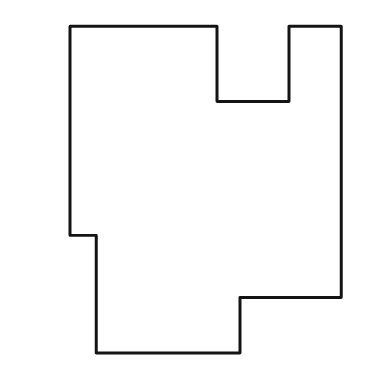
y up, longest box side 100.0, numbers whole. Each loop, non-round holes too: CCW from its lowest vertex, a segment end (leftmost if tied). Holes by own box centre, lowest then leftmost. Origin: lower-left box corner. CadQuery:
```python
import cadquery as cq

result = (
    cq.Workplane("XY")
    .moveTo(8.0, 0.0)
    .lineTo(52.0, 0.0)
    .lineTo(52.0, 17.0)
    .lineTo(83.0, 17.0)
    .lineTo(83.0, 100.0)
    .lineTo(67.0, 100.0)
    .lineTo(67.0, 77.0)
    .lineTo(45.0, 77.0)
    .lineTo(45.0, 100.0)
    .lineTo(0.0, 100.0)
    .lineTo(0.0, 36.0)
    .lineTo(8.0, 36.0)
    .close()
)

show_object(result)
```